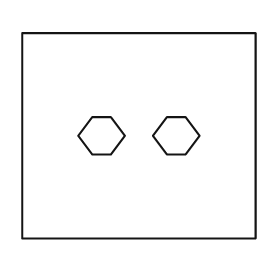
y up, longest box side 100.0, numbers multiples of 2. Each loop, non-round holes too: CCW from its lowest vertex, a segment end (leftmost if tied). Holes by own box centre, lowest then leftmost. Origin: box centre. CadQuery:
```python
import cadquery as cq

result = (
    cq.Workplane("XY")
    .moveTo(-50.0, -44.0)
    .lineTo(50.0, -44.0)
    .lineTo(50.0, 44.0)
    .lineTo(-50.0, 44.0)
    .close()
    .moveTo(-20.0, -8.0)
    .lineTo(-12.0, -8.0)
    .lineTo(-6.0, 0.0)
    .lineTo(-12.0, 8.0)
    .lineTo(-20.0, 8.0)
    .lineTo(-26.0, 0.0)
    .close()
    .moveTo(12.0, -8.0)
    .lineTo(20.0, -8.0)
    .lineTo(26.0, 0.0)
    .lineTo(20.0, 8.0)
    .lineTo(12.0, 8.0)
    .lineTo(6.0, 0.0)
    .close()
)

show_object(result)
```